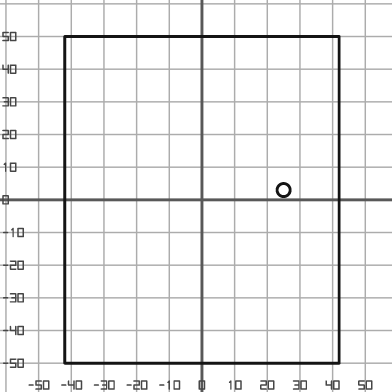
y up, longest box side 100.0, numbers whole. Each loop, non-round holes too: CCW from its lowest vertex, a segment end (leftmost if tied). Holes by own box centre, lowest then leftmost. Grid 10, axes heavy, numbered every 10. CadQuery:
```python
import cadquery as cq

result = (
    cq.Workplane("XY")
    .moveTo(-42.0, -50.0)
    .lineTo(42.0, -50.0)
    .lineTo(42.0, 50.0)
    .lineTo(-42.0, 50.0)
    .close()
    .moveTo(25.0, 3.0)
    .circle(2.0)
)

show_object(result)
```